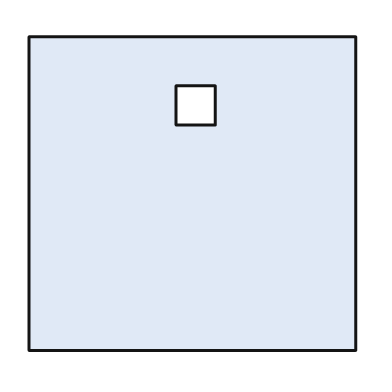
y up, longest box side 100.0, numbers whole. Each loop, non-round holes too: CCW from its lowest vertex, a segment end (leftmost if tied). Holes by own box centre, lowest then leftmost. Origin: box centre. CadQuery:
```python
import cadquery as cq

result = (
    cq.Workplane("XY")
    .moveTo(-50.0, -48.0)
    .lineTo(50.0, -48.0)
    .lineTo(50.0, 48.0)
    .lineTo(-50.0, 48.0)
    .close()
    .moveTo(-5.0, 21.0)
    .lineTo(7.0, 21.0)
    .lineTo(7.0, 33.0)
    .lineTo(-5.0, 33.0)
    .close()
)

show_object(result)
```